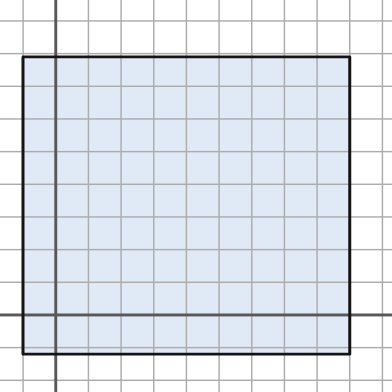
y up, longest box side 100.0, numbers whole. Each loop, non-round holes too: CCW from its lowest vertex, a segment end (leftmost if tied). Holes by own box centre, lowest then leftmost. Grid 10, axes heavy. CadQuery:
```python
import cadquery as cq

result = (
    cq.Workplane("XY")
    .moveTo(-10.0, -12.0)
    .lineTo(90.0, -12.0)
    .lineTo(90.0, 79.0)
    .lineTo(-10.0, 79.0)
    .close()
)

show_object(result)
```